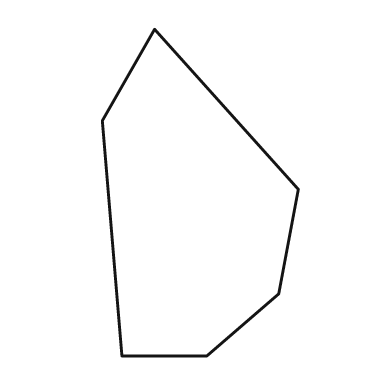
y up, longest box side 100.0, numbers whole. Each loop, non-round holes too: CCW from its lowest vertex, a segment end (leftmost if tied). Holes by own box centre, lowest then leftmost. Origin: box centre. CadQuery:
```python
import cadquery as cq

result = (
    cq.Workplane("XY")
    .moveTo(-24.0, -50.0)
    .lineTo(2.0, -50.0)
    .lineTo(24.0, -31.0)
    .lineTo(30.0, 1.0)
    .lineTo(-14.0, 50.0)
    .lineTo(-30.0, 22.0)
    .close()
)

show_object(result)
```